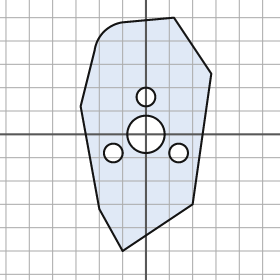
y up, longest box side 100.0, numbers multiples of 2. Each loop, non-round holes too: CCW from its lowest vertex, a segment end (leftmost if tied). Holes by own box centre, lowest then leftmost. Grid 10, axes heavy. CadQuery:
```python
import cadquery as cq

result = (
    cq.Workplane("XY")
    .moveTo(-10.0, -50.0)
    .lineTo(20.0, -30.0)
    .lineTo(28.0, 26.0)
    .lineTo(12.0, 50.0)
    .lineTo(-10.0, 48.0)
    .threePointArc((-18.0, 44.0), (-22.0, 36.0))
    .lineTo(-28.0, 12.0)
    .lineTo(-20.0, -32.0)
    .close()
    .moveTo(-14.0, -8.0)
    .circle(4.0)
    .moveTo(14.0, -8.0)
    .circle(4.0)
    .moveTo(0.0, 0.0)
    .circle(8.0)
    .moveTo(0.0, 16.0)
    .circle(4.0)
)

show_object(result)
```